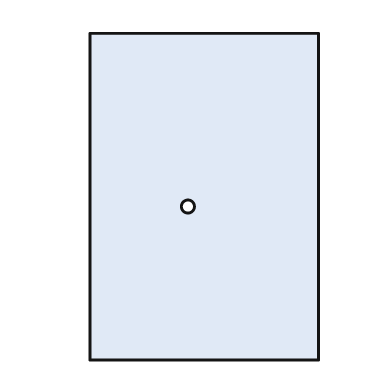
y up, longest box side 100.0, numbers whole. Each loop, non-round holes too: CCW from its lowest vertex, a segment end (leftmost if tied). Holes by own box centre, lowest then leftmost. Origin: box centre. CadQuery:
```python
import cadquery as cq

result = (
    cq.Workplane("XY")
    .moveTo(-35.0, -50.0)
    .lineTo(35.0, -50.0)
    .lineTo(35.0, 50.0)
    .lineTo(-35.0, 50.0)
    .close()
    .moveTo(-5.0, -3.0)
    .circle(2.0)
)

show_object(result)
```